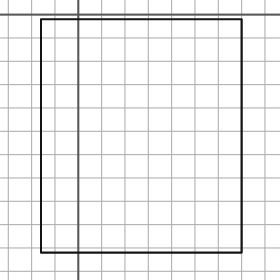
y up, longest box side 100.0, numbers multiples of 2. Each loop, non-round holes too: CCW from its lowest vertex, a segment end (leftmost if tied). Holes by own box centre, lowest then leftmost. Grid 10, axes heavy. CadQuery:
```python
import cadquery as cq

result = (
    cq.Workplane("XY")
    .moveTo(-16.0, -102.0)
    .lineTo(70.0, -102.0)
    .lineTo(70.0, -2.0)
    .lineTo(-16.0, -2.0)
    .close()
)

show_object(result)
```